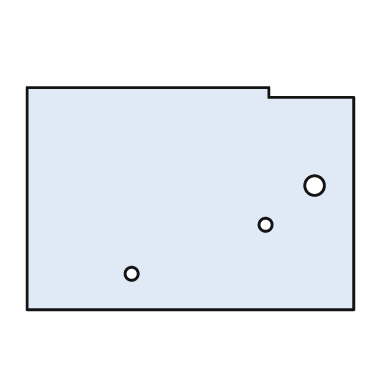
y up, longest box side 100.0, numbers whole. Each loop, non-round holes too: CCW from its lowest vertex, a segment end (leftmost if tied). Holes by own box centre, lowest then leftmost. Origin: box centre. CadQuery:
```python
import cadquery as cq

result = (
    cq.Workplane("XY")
    .moveTo(-50.0, -34.0)
    .lineTo(50.0, -34.0)
    .lineTo(50.0, 31.0)
    .lineTo(24.0, 31.0)
    .lineTo(24.0, 34.0)
    .lineTo(-50.0, 34.0)
    .close()
    .moveTo(-18.0, -23.0)
    .circle(2.0)
    .moveTo(23.0, -8.0)
    .circle(2.0)
    .moveTo(38.0, 4.0)
    .circle(3.0)
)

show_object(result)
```